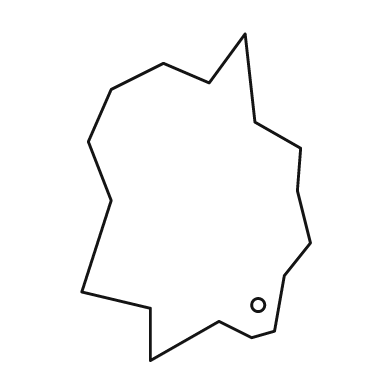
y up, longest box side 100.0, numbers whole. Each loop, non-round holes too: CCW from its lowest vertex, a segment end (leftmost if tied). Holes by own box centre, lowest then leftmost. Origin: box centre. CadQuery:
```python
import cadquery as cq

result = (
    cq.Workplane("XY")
    .moveTo(-14.0, -50.0)
    .lineTo(7.0, -38.0)
    .lineTo(17.0, -43.0)
    .lineTo(24.0, -41.0)
    .lineTo(27.0, -24.0)
    .lineTo(35.0, -14.0)
    .lineTo(31.0, 2.0)
    .lineTo(32.0, 15.0)
    .lineTo(18.0, 23.0)
    .lineTo(15.0, 50.0)
    .lineTo(4.0, 35.0)
    .lineTo(-10.0, 41.0)
    .lineTo(-26.0, 33.0)
    .lineTo(-33.0, 17.0)
    .lineTo(-26.0, -1.0)
    .lineTo(-35.0, -29.0)
    .lineTo(-14.0, -34.0)
    .close()
    .moveTo(19.0, -33.0)
    .circle(2.0)
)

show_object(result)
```